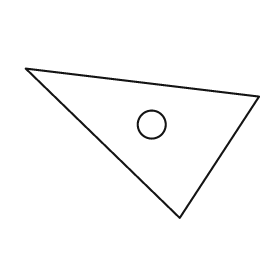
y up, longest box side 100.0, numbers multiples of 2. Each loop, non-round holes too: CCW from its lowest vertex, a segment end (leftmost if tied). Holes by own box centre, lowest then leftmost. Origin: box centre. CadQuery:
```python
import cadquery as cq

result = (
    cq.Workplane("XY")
    .moveTo(16.0, -32.0)
    .lineTo(50.0, 20.0)
    .lineTo(-50.0, 32.0)
    .close()
    .moveTo(4.0, 8.0)
    .circle(6.0)
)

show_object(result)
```